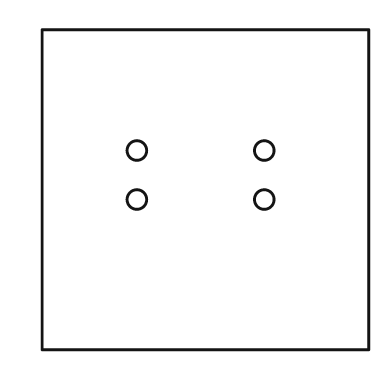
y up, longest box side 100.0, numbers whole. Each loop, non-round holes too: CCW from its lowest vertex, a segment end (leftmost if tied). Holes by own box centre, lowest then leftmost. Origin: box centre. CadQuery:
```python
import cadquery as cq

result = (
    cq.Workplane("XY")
    .moveTo(-50.0, -49.0)
    .lineTo(50.0, -49.0)
    .lineTo(50.0, 49.0)
    .lineTo(-50.0, 49.0)
    .close()
    .moveTo(-21.0, -3.0)
    .circle(3.0)
    .moveTo(18.0, -3.0)
    .circle(3.0)
    .moveTo(-21.0, 12.0)
    .circle(3.0)
    .moveTo(18.0, 12.0)
    .circle(3.0)
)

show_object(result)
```